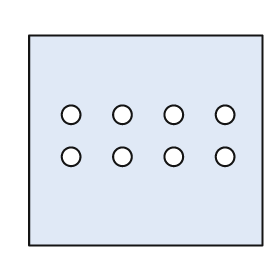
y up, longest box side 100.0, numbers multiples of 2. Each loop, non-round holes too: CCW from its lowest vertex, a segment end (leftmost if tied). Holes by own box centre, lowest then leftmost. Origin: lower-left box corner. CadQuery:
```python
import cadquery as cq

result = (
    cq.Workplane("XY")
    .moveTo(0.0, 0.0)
    .lineTo(100.0, 0.0)
    .lineTo(100.0, 90.0)
    .lineTo(0.0, 90.0)
    .close()
    .moveTo(18.0, 38.0)
    .circle(4.0)
    .moveTo(40.0, 38.0)
    .circle(4.0)
    .moveTo(62.0, 38.0)
    .circle(4.0)
    .moveTo(84.0, 38.0)
    .circle(4.0)
    .moveTo(18.0, 56.0)
    .circle(4.0)
    .moveTo(40.0, 56.0)
    .circle(4.0)
    .moveTo(62.0, 56.0)
    .circle(4.0)
    .moveTo(84.0, 56.0)
    .circle(4.0)
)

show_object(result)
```